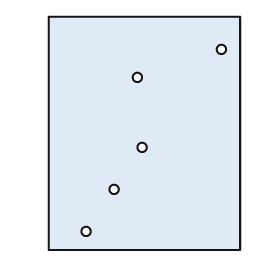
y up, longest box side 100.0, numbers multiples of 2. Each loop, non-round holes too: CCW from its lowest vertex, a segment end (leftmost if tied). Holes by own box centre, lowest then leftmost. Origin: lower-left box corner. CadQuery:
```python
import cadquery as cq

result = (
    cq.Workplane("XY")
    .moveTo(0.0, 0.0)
    .lineTo(82.0, 0.0)
    .lineTo(82.0, 100.0)
    .lineTo(0.0, 100.0)
    .close()
    .moveTo(16.0, 8.0)
    .circle(2.0)
    .moveTo(28.0, 26.0)
    .circle(2.0)
    .moveTo(40.0, 44.0)
    .circle(2.0)
    .moveTo(38.0, 74.0)
    .circle(2.0)
    .moveTo(74.0, 86.0)
    .circle(2.0)
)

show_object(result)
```